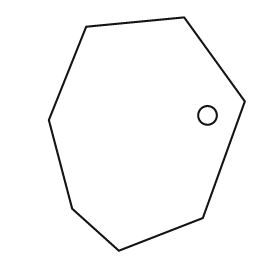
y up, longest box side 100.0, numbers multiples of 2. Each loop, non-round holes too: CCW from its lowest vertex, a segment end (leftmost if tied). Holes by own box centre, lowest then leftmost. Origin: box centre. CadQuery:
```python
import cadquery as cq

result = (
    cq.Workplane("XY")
    .moveTo(-12.0, -50.0)
    .lineTo(24.0, -36.0)
    .lineTo(42.0, 14.0)
    .lineTo(16.0, 50.0)
    .lineTo(-26.0, 46.0)
    .lineTo(-42.0, 6.0)
    .lineTo(-32.0, -32.0)
    .close()
    .moveTo(26.0, 8.0)
    .circle(4.0)
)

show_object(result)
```